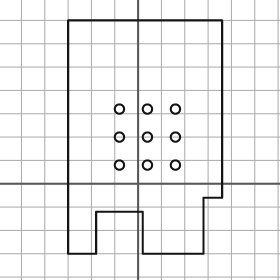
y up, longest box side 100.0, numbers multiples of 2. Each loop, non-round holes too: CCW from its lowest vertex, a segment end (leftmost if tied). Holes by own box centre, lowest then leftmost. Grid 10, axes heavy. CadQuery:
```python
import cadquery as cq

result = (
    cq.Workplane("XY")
    .moveTo(-30.0, -30.0)
    .lineTo(-18.0, -30.0)
    .lineTo(-18.0, -12.0)
    .lineTo(2.0, -12.0)
    .lineTo(2.0, -30.0)
    .lineTo(28.0, -30.0)
    .lineTo(28.0, -6.0)
    .lineTo(36.0, -6.0)
    .lineTo(36.0, 70.0)
    .lineTo(-30.0, 70.0)
    .close()
    .moveTo(-8.0, 8.0)
    .circle(2.0)
    .moveTo(4.0, 8.0)
    .circle(2.0)
    .moveTo(16.0, 8.0)
    .circle(2.0)
    .moveTo(-8.0, 20.0)
    .circle(2.0)
    .moveTo(4.0, 20.0)
    .circle(2.0)
    .moveTo(16.0, 20.0)
    .circle(2.0)
    .moveTo(-8.0, 32.0)
    .circle(2.0)
    .moveTo(4.0, 32.0)
    .circle(2.0)
    .moveTo(16.0, 32.0)
    .circle(2.0)
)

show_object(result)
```